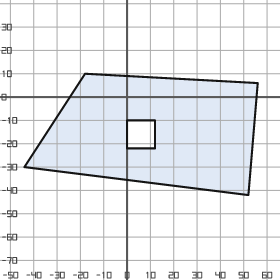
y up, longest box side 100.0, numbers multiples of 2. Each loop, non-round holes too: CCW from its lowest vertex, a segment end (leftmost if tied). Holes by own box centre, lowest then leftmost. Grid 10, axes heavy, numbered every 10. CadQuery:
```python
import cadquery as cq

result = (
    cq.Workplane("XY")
    .moveTo(52.0, -42.0)
    .lineTo(56.0, 6.0)
    .lineTo(-18.0, 10.0)
    .lineTo(-44.0, -30.0)
    .close()
    .moveTo(0.0, -22.0)
    .lineTo(12.0, -22.0)
    .lineTo(12.0, -10.0)
    .lineTo(0.0, -10.0)
    .close()
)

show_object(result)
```